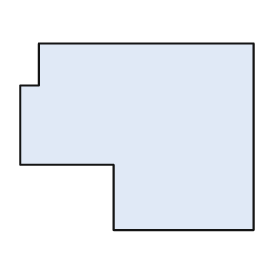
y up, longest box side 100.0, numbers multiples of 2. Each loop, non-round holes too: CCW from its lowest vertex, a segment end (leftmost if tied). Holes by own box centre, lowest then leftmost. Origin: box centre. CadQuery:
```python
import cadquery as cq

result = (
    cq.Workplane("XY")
    .moveTo(-10.0, -40.0)
    .lineTo(50.0, -40.0)
    .lineTo(50.0, 40.0)
    .lineTo(-42.0, 40.0)
    .lineTo(-42.0, 22.0)
    .lineTo(-50.0, 22.0)
    .lineTo(-50.0, -12.0)
    .lineTo(-10.0, -12.0)
    .close()
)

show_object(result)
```